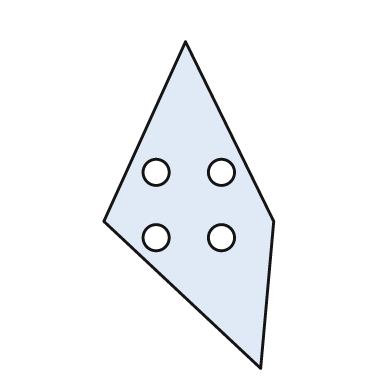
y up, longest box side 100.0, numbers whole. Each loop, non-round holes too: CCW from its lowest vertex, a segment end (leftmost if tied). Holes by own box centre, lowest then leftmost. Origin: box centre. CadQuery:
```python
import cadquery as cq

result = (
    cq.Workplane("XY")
    .moveTo(22.0, -50.0)
    .lineTo(26.0, -5.0)
    .lineTo(-1.0, 50.0)
    .lineTo(-26.0, -5.0)
    .close()
    .moveTo(-10.0, -10.0)
    .circle(4.0)
    .moveTo(10.0, -10.0)
    .circle(4.0)
    .moveTo(-10.0, 10.0)
    .circle(4.0)
    .moveTo(10.0, 10.0)
    .circle(4.0)
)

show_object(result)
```